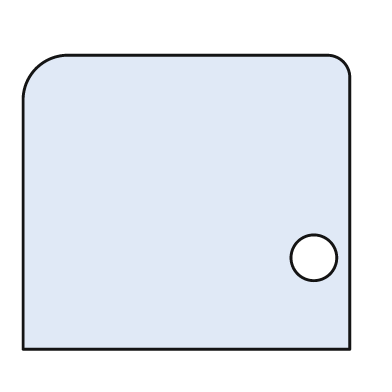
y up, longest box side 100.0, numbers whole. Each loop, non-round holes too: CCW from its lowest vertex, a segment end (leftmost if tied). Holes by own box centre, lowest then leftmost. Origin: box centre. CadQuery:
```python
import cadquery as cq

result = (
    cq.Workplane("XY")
    .moveTo(-50.0, -45.0)
    .lineTo(50.0, -45.0)
    .lineTo(50.0, 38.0)
    .threePointArc((48.0, 43.0), (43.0, 45.0))
    .lineTo(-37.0, 45.0)
    .threePointArc((-46.0, 41.0), (-50.0, 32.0))
    .close()
    .moveTo(39.0, -17.0)
    .circle(7.0)
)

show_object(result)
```